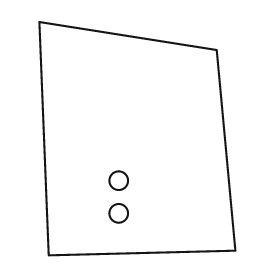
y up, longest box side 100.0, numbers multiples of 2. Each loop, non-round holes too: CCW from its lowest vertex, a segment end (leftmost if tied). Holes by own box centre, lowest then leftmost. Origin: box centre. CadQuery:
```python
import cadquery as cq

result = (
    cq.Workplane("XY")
    .moveTo(-38.0, -50.0)
    .lineTo(42.0, -48.0)
    .lineTo(34.0, 38.0)
    .lineTo(-42.0, 50.0)
    .close()
    .moveTo(-8.0, -32.0)
    .circle(4.0)
    .moveTo(-8.0, -18.0)
    .circle(4.0)
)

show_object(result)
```